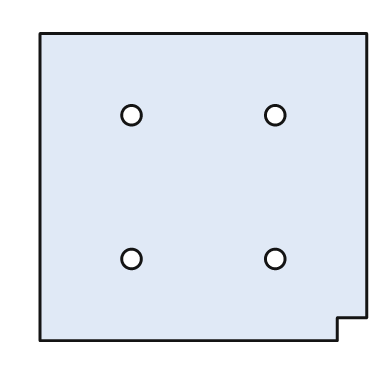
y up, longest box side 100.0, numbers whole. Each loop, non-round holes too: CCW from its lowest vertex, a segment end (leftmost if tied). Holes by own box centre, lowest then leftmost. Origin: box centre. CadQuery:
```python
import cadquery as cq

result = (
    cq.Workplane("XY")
    .moveTo(-50.0, -47.0)
    .lineTo(41.0, -47.0)
    .lineTo(41.0, -40.0)
    .lineTo(50.0, -40.0)
    .lineTo(50.0, 47.0)
    .lineTo(-50.0, 47.0)
    .close()
    .moveTo(-22.0, -22.0)
    .circle(3.0)
    .moveTo(22.0, -22.0)
    .circle(3.0)
    .moveTo(-22.0, 22.0)
    .circle(3.0)
    .moveTo(22.0, 22.0)
    .circle(3.0)
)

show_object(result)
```